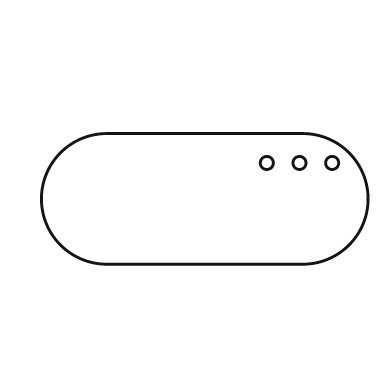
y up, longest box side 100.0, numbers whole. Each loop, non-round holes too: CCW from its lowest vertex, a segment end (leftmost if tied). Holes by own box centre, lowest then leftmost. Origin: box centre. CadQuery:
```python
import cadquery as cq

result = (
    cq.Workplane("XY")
    .moveTo(-30.0, -20.0)
    .lineTo(30.0, -20.0)
    .threePointArc((50.0, 0.0), (30.0, 20.0))
    .lineTo(-30.0, 20.0)
    .threePointArc((-50.0, 0.0), (-30.0, -20.0))
    .close()
    .moveTo(19.0, 11.0)
    .circle(2.0)
    .moveTo(29.0, 11.0)
    .circle(2.0)
    .moveTo(39.0, 11.0)
    .circle(2.0)
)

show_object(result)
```